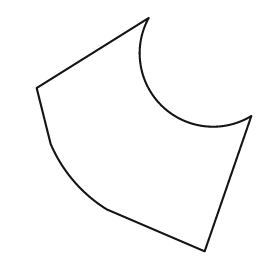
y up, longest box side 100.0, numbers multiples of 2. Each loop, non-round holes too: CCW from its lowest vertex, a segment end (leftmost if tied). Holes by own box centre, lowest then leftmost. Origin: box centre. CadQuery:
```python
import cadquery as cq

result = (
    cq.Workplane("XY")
    .moveTo(26.0, -50.0)
    .lineTo(46.0, 8.0)
    .threePointArc((8.0, 12.0), (2.0, 50.0))
    .lineTo(-46.0, 20.0)
    .lineTo(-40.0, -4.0)
    .threePointArc((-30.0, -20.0), (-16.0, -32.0))
    .close()
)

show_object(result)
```